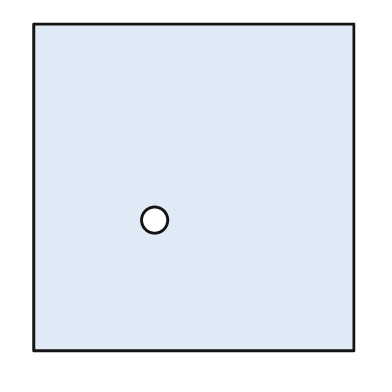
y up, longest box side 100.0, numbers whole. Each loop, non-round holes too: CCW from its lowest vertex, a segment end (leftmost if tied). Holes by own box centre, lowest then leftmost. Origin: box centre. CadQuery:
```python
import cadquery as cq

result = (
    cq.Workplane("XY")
    .moveTo(-49.0, -50.0)
    .lineTo(49.0, -50.0)
    .lineTo(49.0, 50.0)
    .lineTo(-49.0, 50.0)
    .close()
    .moveTo(-12.0, -10.0)
    .circle(4.0)
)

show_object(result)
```